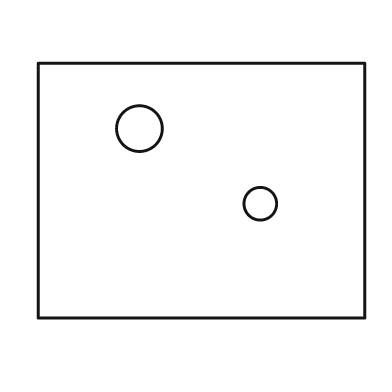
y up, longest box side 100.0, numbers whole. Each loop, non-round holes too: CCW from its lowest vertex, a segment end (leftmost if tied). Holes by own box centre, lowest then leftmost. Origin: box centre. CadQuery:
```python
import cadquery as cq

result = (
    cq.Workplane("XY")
    .moveTo(-50.0, -39.0)
    .lineTo(50.0, -39.0)
    .lineTo(50.0, 39.0)
    .lineTo(-50.0, 39.0)
    .close()
    .moveTo(18.0, -4.0)
    .circle(5.0)
    .moveTo(-19.0, 19.0)
    .circle(7.0)
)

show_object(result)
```